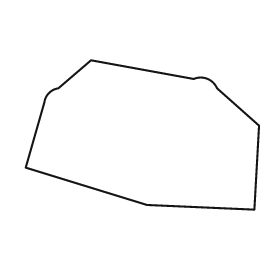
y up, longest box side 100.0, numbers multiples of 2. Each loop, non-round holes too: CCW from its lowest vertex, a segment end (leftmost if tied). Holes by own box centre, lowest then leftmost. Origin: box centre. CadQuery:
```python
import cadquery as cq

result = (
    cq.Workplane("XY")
    .moveTo(48.0, -32.0)
    .lineTo(50.0, 4.0)
    .lineTo(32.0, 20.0)
    .threePointArc((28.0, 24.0), (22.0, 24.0))
    .lineTo(-22.0, 32.0)
    .lineTo(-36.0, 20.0)
    .threePointArc((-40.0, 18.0), (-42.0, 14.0))
    .lineTo(-50.0, -14.0)
    .lineTo(2.0, -30.0)
    .close()
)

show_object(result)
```